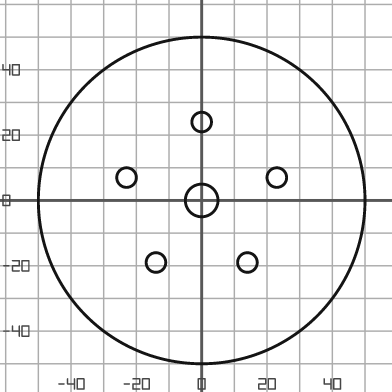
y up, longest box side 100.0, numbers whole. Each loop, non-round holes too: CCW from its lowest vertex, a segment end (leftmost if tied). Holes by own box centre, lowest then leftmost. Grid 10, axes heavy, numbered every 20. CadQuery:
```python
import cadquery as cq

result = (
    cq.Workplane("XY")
    .moveTo(0.0, 0.0)
    .circle(50.0)
    .moveTo(-14.0, -19.0)
    .circle(3.0)
    .moveTo(14.0, -19.0)
    .circle(3.0)
    .moveTo(0.0, 0.0)
    .circle(5.0)
    .moveTo(-23.0, 7.0)
    .circle(3.0)
    .moveTo(23.0, 7.0)
    .circle(3.0)
    .moveTo(0.0, 24.0)
    .circle(3.0)
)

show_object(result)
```